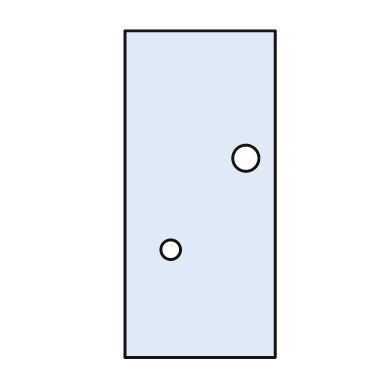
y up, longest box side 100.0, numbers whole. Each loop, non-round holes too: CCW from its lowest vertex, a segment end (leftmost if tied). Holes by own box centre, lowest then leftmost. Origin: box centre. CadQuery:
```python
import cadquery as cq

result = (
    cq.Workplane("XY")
    .moveTo(-23.0, -50.0)
    .lineTo(23.0, -50.0)
    .lineTo(23.0, 50.0)
    .lineTo(-23.0, 50.0)
    .close()
    .moveTo(-9.0, -17.0)
    .circle(3.0)
    .moveTo(14.0, 11.0)
    .circle(4.0)
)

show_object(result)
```